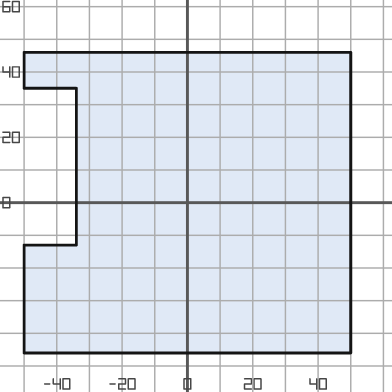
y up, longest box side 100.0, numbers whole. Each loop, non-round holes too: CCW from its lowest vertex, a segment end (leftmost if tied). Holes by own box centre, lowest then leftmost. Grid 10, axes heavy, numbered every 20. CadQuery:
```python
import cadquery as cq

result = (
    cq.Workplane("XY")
    .moveTo(-50.0, -46.0)
    .lineTo(50.0, -46.0)
    .lineTo(50.0, 46.0)
    .lineTo(-50.0, 46.0)
    .lineTo(-50.0, 35.0)
    .lineTo(-34.0, 35.0)
    .lineTo(-34.0, -13.0)
    .lineTo(-50.0, -13.0)
    .close()
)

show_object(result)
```